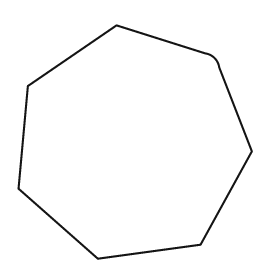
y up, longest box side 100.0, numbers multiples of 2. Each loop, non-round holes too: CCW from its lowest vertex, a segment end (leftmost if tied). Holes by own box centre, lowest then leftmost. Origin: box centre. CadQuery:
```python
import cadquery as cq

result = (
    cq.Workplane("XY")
    .moveTo(-16.0, -50.0)
    .lineTo(28.0, -44.0)
    .lineTo(50.0, -4.0)
    .lineTo(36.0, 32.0)
    .threePointArc((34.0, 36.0), (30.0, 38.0))
    .lineTo(-8.0, 50.0)
    .lineTo(-46.0, 24.0)
    .lineTo(-50.0, -20.0)
    .close()
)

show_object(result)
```